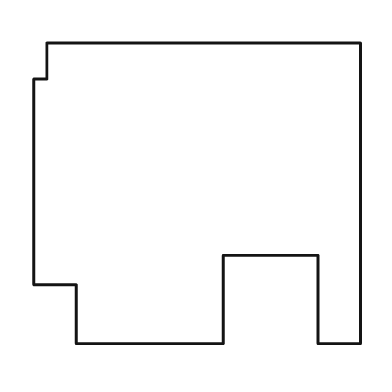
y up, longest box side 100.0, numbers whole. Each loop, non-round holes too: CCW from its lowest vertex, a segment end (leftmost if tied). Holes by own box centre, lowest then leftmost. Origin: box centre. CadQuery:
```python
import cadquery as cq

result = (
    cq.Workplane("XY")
    .moveTo(-37.0, -46.0)
    .lineTo(8.0, -46.0)
    .lineTo(8.0, -19.0)
    .lineTo(37.0, -19.0)
    .lineTo(37.0, -46.0)
    .lineTo(50.0, -46.0)
    .lineTo(50.0, 46.0)
    .lineTo(-46.0, 46.0)
    .lineTo(-46.0, 35.0)
    .lineTo(-50.0, 35.0)
    .lineTo(-50.0, -28.0)
    .lineTo(-37.0, -28.0)
    .close()
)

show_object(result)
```